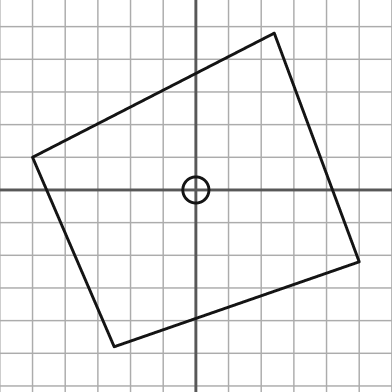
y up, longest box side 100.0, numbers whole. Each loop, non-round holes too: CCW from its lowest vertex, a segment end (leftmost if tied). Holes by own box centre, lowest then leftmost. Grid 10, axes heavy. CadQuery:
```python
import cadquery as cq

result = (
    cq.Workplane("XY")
    .moveTo(-25.0, -48.0)
    .lineTo(50.0, -22.0)
    .lineTo(24.0, 48.0)
    .lineTo(-50.0, 10.0)
    .close()
    .moveTo(0.0, 0.0)
    .circle(4.0)
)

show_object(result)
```